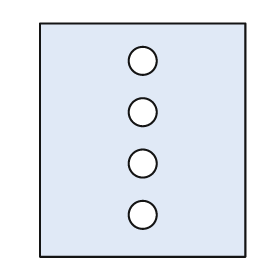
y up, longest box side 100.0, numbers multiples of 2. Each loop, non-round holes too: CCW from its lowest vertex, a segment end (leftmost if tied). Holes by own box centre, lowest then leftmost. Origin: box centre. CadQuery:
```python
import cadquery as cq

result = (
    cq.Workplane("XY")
    .moveTo(-44.0, -50.0)
    .lineTo(44.0, -50.0)
    .lineTo(44.0, 50.0)
    .lineTo(-44.0, 50.0)
    .close()
    .moveTo(0.0, -32.0)
    .circle(6.0)
    .moveTo(0.0, -10.0)
    .circle(6.0)
    .moveTo(0.0, 12.0)
    .circle(6.0)
    .moveTo(0.0, 34.0)
    .circle(6.0)
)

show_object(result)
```